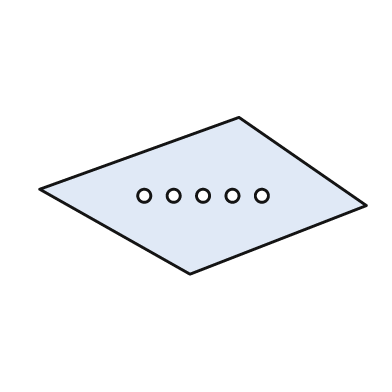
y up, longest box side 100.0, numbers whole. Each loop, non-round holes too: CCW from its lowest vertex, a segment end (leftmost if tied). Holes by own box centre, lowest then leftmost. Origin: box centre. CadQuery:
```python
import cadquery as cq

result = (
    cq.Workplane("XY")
    .moveTo(-4.0, -24.0)
    .lineTo(50.0, -3.0)
    .lineTo(11.0, 24.0)
    .lineTo(-50.0, 2.0)
    .close()
    .moveTo(-18.0, 0.0)
    .circle(2.0)
    .moveTo(-9.0, 0.0)
    .circle(2.0)
    .moveTo(0.0, 0.0)
    .circle(2.0)
    .moveTo(9.0, 0.0)
    .circle(2.0)
    .moveTo(18.0, 0.0)
    .circle(2.0)
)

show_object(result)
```